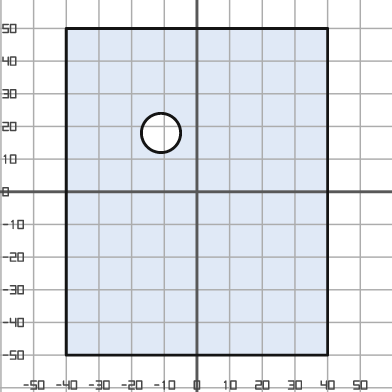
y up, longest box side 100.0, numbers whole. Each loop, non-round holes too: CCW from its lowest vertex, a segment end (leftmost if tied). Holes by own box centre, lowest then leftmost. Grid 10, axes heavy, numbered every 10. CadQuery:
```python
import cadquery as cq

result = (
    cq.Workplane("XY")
    .moveTo(-40.0, -50.0)
    .lineTo(40.0, -50.0)
    .lineTo(40.0, 50.0)
    .lineTo(-40.0, 50.0)
    .close()
    .moveTo(-11.0, 18.0)
    .circle(6.0)
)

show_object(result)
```